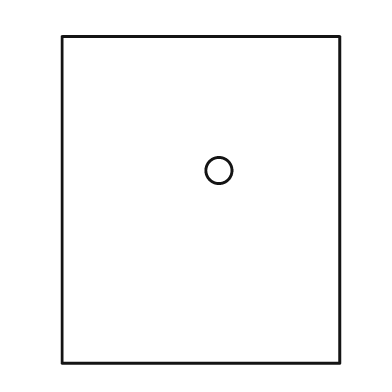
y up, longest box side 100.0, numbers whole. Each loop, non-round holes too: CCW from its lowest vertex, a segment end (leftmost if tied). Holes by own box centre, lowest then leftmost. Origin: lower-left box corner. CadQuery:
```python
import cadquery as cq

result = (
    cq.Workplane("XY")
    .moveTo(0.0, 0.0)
    .lineTo(85.0, 0.0)
    .lineTo(85.0, 100.0)
    .lineTo(0.0, 100.0)
    .close()
    .moveTo(48.0, 59.0)
    .circle(4.0)
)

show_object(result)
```